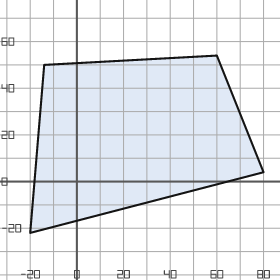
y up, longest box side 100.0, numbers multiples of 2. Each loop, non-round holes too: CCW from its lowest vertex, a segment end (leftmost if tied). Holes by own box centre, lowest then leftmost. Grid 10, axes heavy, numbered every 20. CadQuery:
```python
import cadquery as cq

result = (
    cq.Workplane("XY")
    .moveTo(-20.0, -22.0)
    .lineTo(80.0, 4.0)
    .lineTo(60.0, 54.0)
    .lineTo(-14.0, 50.0)
    .close()
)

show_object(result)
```